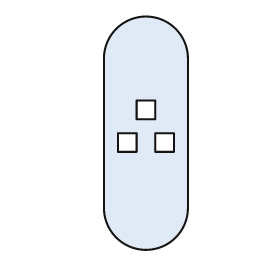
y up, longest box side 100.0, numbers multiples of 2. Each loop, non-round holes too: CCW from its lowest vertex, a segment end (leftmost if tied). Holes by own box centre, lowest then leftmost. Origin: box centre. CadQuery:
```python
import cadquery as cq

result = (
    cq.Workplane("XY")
    .moveTo(-18.0, -32.0)
    .threePointArc((0.0, -50.0), (18.0, -32.0))
    .lineTo(18.0, 32.0)
    .threePointArc((0.0, 50.0), (-18.0, 32.0))
    .close()
    .moveTo(-12.0, -8.0)
    .lineTo(-4.0, -8.0)
    .lineTo(-4.0, 0.0)
    .lineTo(-12.0, 0.0)
    .close()
    .moveTo(4.0, -8.0)
    .lineTo(12.0, -8.0)
    .lineTo(12.0, 0.0)
    .lineTo(4.0, 0.0)
    .close()
    .moveTo(-4.0, 6.0)
    .lineTo(4.0, 6.0)
    .lineTo(4.0, 14.0)
    .lineTo(-4.0, 14.0)
    .close()
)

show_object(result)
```